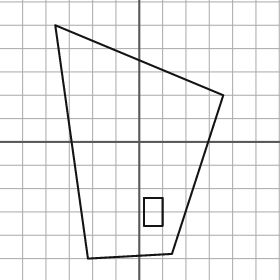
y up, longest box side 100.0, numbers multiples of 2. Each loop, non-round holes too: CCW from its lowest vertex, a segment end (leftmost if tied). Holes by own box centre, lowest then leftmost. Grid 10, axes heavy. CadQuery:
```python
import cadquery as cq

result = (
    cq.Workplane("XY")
    .moveTo(-22.0, -50.0)
    .lineTo(14.0, -48.0)
    .lineTo(36.0, 20.0)
    .lineTo(-36.0, 50.0)
    .close()
    .moveTo(2.0, -36.0)
    .lineTo(10.0, -36.0)
    .lineTo(10.0, -24.0)
    .lineTo(2.0, -24.0)
    .close()
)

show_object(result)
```